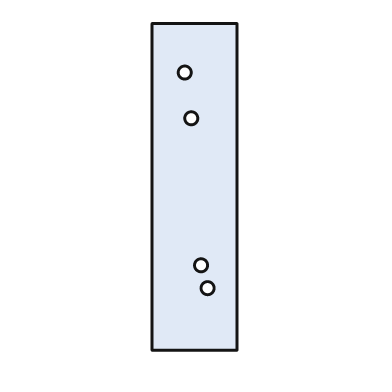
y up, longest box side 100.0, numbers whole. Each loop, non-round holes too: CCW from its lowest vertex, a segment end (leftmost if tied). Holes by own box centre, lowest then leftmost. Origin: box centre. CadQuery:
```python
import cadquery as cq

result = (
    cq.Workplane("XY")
    .moveTo(-13.0, -50.0)
    .lineTo(13.0, -50.0)
    .lineTo(13.0, 50.0)
    .lineTo(-13.0, 50.0)
    .close()
    .moveTo(4.0, -31.0)
    .circle(2.0)
    .moveTo(2.0, -24.0)
    .circle(2.0)
    .moveTo(-1.0, 21.0)
    .circle(2.0)
    .moveTo(-3.0, 35.0)
    .circle(2.0)
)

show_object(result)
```